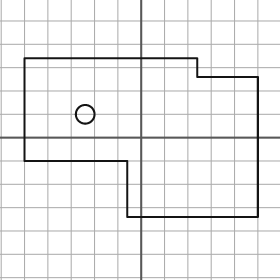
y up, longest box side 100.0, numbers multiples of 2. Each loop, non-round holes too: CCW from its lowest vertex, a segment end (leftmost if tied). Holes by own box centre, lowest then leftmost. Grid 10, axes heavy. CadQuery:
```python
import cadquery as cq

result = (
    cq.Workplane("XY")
    .moveTo(-6.0, -34.0)
    .lineTo(50.0, -34.0)
    .lineTo(50.0, 26.0)
    .lineTo(24.0, 26.0)
    .lineTo(24.0, 34.0)
    .lineTo(-50.0, 34.0)
    .lineTo(-50.0, -10.0)
    .lineTo(-6.0, -10.0)
    .close()
    .moveTo(-24.0, 10.0)
    .circle(4.0)
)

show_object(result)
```